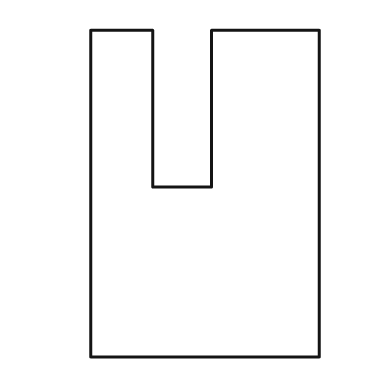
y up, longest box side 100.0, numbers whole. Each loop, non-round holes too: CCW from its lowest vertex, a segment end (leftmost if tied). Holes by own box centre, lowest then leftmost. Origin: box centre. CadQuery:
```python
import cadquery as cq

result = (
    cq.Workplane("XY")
    .moveTo(-35.0, -50.0)
    .lineTo(35.0, -50.0)
    .lineTo(35.0, 50.0)
    .lineTo(2.0, 50.0)
    .lineTo(2.0, 2.0)
    .lineTo(-16.0, 2.0)
    .lineTo(-16.0, 50.0)
    .lineTo(-35.0, 50.0)
    .close()
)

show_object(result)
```